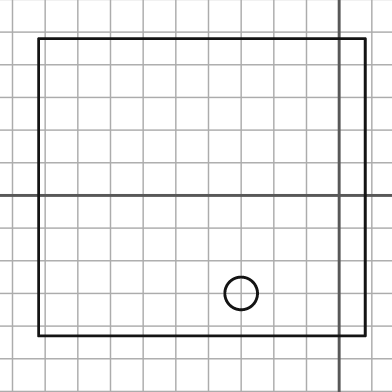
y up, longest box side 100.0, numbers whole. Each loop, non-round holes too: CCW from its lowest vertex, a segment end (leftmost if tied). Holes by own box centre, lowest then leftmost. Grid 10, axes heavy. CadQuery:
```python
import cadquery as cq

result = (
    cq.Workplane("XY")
    .moveTo(-92.0, -43.0)
    .lineTo(8.0, -43.0)
    .lineTo(8.0, 48.0)
    .lineTo(-92.0, 48.0)
    .close()
    .moveTo(-30.0, -30.0)
    .circle(5.0)
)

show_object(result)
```